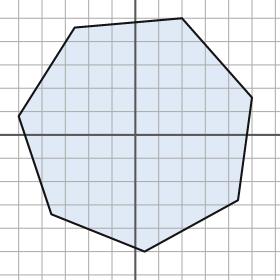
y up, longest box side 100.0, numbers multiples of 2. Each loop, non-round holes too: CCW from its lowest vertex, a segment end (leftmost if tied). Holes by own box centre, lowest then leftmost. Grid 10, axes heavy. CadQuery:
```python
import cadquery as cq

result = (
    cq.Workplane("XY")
    .moveTo(4.0, -50.0)
    .lineTo(44.0, -28.0)
    .lineTo(50.0, 16.0)
    .lineTo(20.0, 50.0)
    .lineTo(-26.0, 46.0)
    .lineTo(-50.0, 8.0)
    .lineTo(-36.0, -34.0)
    .close()
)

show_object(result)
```